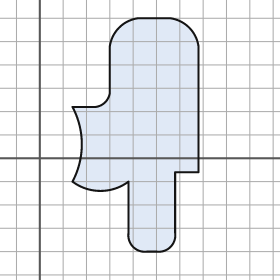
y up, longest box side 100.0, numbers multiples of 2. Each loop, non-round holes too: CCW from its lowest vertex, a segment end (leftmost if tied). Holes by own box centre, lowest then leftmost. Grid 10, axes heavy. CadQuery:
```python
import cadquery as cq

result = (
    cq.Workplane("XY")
    .moveTo(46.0, -40.0)
    .lineTo(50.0, -40.0)
    .threePointArc((56.0, -38.0), (58.0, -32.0))
    .lineTo(58.0, -6.0)
    .lineTo(68.0, -6.0)
    .lineTo(68.0, 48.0)
    .threePointArc((64.0, 56.0), (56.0, 60.0))
    .lineTo(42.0, 60.0)
    .threePointArc((34.0, 56.0), (30.0, 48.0))
    .lineTo(30.0, 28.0)
    .threePointArc((28.0, 24.0), (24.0, 22.0))
    .lineTo(14.0, 22.0)
    .threePointArc((18.0, 6.0), (14.0, -10.0))
    .threePointArc((26.0, -14.0), (38.0, -10.0))
    .lineTo(38.0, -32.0)
    .threePointArc((40.0, -38.0), (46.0, -40.0))
    .close()
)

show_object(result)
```